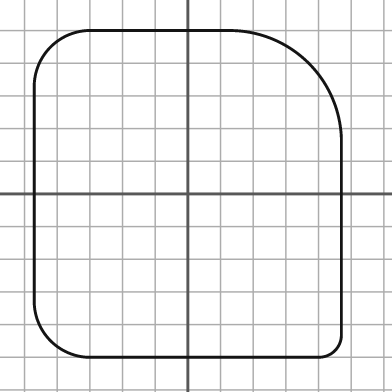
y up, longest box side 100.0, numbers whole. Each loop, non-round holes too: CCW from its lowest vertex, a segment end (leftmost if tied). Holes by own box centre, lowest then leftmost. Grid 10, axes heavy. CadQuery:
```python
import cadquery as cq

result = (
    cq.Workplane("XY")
    .moveTo(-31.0, -50.0)
    .lineTo(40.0, -50.0)
    .threePointArc((45.0, -48.0), (47.0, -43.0))
    .lineTo(47.0, 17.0)
    .threePointArc((37.0, 40.0), (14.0, 50.0))
    .lineTo(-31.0, 50.0)
    .threePointArc((-42.0, 45.0), (-47.0, 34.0))
    .lineTo(-47.0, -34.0)
    .threePointArc((-42.0, -45.0), (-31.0, -50.0))
    .close()
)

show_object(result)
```